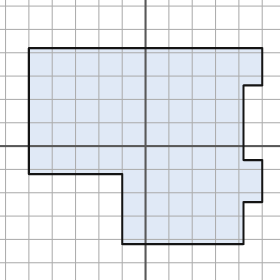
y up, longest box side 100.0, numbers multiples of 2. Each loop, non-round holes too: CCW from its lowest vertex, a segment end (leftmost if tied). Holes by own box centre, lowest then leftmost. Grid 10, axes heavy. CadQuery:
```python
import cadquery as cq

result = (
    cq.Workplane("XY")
    .moveTo(-10.0, -42.0)
    .lineTo(42.0, -42.0)
    .lineTo(42.0, -24.0)
    .lineTo(50.0, -24.0)
    .lineTo(50.0, -6.0)
    .lineTo(42.0, -6.0)
    .lineTo(42.0, 26.0)
    .lineTo(50.0, 26.0)
    .lineTo(50.0, 42.0)
    .lineTo(-50.0, 42.0)
    .lineTo(-50.0, -12.0)
    .lineTo(-10.0, -12.0)
    .close()
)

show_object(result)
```